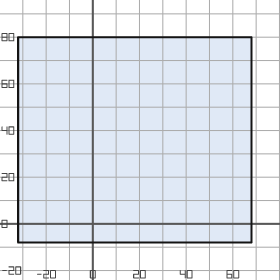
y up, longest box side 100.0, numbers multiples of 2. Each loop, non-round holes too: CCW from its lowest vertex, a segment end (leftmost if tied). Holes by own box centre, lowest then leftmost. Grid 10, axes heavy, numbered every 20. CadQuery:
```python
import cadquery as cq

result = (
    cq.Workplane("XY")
    .moveTo(-32.0, -8.0)
    .lineTo(68.0, -8.0)
    .lineTo(68.0, 80.0)
    .lineTo(-32.0, 80.0)
    .close()
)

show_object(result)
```